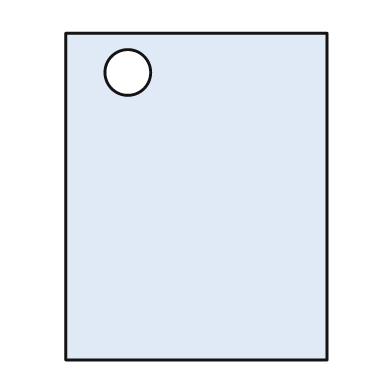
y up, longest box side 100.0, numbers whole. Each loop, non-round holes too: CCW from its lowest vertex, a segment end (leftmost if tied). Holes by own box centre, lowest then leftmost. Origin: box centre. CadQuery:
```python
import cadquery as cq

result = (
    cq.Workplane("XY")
    .moveTo(-40.0, -50.0)
    .lineTo(40.0, -50.0)
    .lineTo(40.0, 50.0)
    .lineTo(-40.0, 50.0)
    .close()
    .moveTo(-21.0, 38.0)
    .circle(7.0)
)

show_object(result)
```